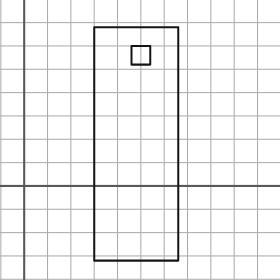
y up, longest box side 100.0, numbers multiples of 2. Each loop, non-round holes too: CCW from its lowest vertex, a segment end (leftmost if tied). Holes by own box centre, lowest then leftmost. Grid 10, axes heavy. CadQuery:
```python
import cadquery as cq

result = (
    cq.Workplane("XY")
    .moveTo(30.0, -32.0)
    .lineTo(66.0, -32.0)
    .lineTo(66.0, 68.0)
    .lineTo(30.0, 68.0)
    .close()
    .moveTo(46.0, 52.0)
    .lineTo(54.0, 52.0)
    .lineTo(54.0, 60.0)
    .lineTo(46.0, 60.0)
    .close()
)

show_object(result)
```